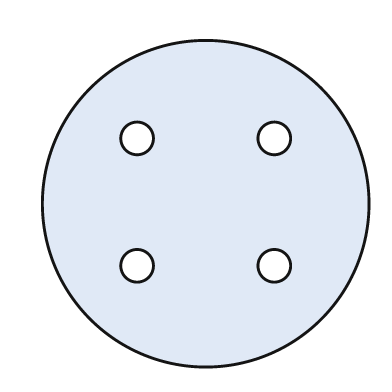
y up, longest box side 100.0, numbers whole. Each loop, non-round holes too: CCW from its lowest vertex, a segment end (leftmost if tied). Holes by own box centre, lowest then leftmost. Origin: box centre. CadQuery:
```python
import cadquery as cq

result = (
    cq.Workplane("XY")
    .moveTo(0.0, 0.0)
    .circle(50.0)
    .moveTo(-21.0, -19.0)
    .circle(5.0)
    .moveTo(21.0, -19.0)
    .circle(5.0)
    .moveTo(-21.0, 20.0)
    .circle(5.0)
    .moveTo(21.0, 20.0)
    .circle(5.0)
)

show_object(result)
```